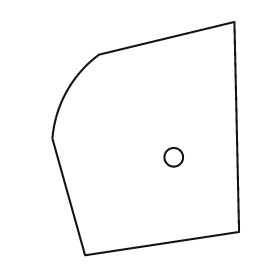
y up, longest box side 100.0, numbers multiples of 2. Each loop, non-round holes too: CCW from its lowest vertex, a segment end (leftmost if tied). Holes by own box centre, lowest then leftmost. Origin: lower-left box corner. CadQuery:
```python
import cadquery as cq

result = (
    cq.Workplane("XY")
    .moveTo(14.0, 0.0)
    .lineTo(80.0, 10.0)
    .lineTo(78.0, 100.0)
    .lineTo(20.0, 86.0)
    .threePointArc((6.0, 70.0), (0.0, 50.0))
    .close()
    .moveTo(52.0, 42.0)
    .circle(4.0)
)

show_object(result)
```